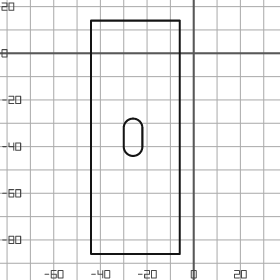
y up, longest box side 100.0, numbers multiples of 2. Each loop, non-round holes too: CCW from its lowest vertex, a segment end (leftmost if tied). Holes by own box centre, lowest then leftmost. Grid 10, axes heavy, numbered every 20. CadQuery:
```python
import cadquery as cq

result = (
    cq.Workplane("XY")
    .moveTo(-44.0, -86.0)
    .lineTo(-6.0, -86.0)
    .lineTo(-6.0, 14.0)
    .lineTo(-44.0, 14.0)
    .close()
    .moveTo(-30.0, -40.0)
    .threePointArc((-26.0, -44.0), (-22.0, -40.0))
    .lineTo(-22.0, -32.0)
    .threePointArc((-26.0, -28.0), (-30.0, -32.0))
    .close()
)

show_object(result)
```